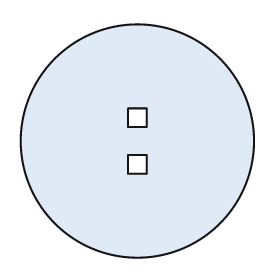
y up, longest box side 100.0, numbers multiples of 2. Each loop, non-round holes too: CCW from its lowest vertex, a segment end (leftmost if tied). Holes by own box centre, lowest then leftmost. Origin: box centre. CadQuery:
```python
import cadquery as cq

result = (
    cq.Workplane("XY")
    .moveTo(0.0, 0.0)
    .circle(50.0)
    .moveTo(-4.0, -14.0)
    .lineTo(4.0, -14.0)
    .lineTo(4.0, -6.0)
    .lineTo(-4.0, -6.0)
    .close()
    .moveTo(-4.0, 6.0)
    .lineTo(4.0, 6.0)
    .lineTo(4.0, 14.0)
    .lineTo(-4.0, 14.0)
    .close()
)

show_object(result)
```